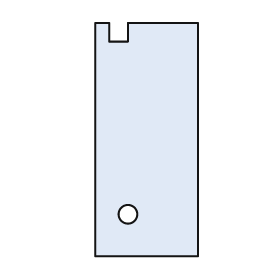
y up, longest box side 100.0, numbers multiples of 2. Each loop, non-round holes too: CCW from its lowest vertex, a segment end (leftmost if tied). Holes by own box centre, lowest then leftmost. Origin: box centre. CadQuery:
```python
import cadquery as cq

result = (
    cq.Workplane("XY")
    .moveTo(-22.0, -50.0)
    .lineTo(22.0, -50.0)
    .lineTo(22.0, 50.0)
    .lineTo(-8.0, 50.0)
    .lineTo(-8.0, 42.0)
    .lineTo(-16.0, 42.0)
    .lineTo(-16.0, 50.0)
    .lineTo(-22.0, 50.0)
    .close()
    .moveTo(-8.0, -32.0)
    .circle(4.0)
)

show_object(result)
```